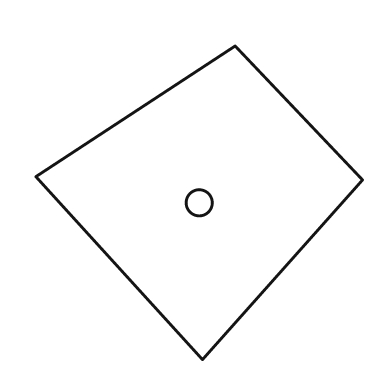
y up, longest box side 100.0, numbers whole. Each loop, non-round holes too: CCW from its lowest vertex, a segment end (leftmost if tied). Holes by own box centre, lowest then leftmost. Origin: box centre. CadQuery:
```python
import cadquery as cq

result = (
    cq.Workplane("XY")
    .moveTo(1.0, -48.0)
    .lineTo(50.0, 7.0)
    .lineTo(11.0, 48.0)
    .lineTo(-50.0, 8.0)
    .close()
    .moveTo(0.0, 0.0)
    .circle(4.0)
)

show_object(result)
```